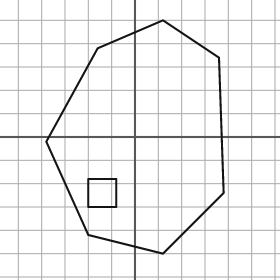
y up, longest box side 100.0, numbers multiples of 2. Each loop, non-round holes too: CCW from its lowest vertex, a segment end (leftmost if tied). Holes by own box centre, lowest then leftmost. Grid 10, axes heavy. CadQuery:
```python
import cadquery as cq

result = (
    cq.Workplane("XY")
    .moveTo(12.0, -50.0)
    .lineTo(38.0, -24.0)
    .lineTo(36.0, 34.0)
    .lineTo(12.0, 50.0)
    .lineTo(-16.0, 38.0)
    .lineTo(-38.0, -2.0)
    .lineTo(-20.0, -42.0)
    .close()
    .moveTo(-20.0, -30.0)
    .lineTo(-8.0, -30.0)
    .lineTo(-8.0, -18.0)
    .lineTo(-20.0, -18.0)
    .close()
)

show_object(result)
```